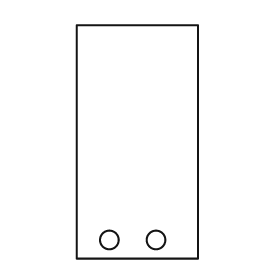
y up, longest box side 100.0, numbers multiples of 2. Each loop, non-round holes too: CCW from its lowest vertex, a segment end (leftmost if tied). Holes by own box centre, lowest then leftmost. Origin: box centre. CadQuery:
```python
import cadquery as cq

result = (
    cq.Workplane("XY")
    .moveTo(-26.0, -50.0)
    .lineTo(26.0, -50.0)
    .lineTo(26.0, 50.0)
    .lineTo(-26.0, 50.0)
    .close()
    .moveTo(-12.0, -42.0)
    .circle(4.0)
    .moveTo(8.0, -42.0)
    .circle(4.0)
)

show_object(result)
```